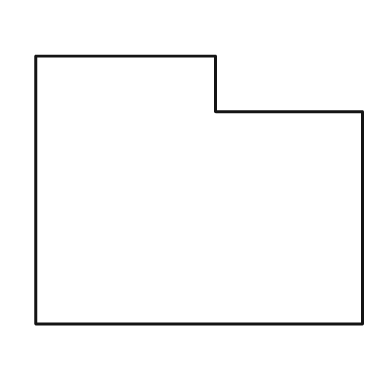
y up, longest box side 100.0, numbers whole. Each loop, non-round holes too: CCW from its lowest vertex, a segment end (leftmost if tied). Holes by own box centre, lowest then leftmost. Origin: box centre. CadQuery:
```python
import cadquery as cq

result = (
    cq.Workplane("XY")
    .moveTo(-50.0, -41.0)
    .lineTo(50.0, -41.0)
    .lineTo(50.0, 24.0)
    .lineTo(5.0, 24.0)
    .lineTo(5.0, 41.0)
    .lineTo(-50.0, 41.0)
    .close()
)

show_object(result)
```